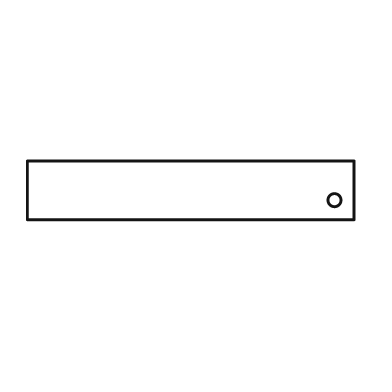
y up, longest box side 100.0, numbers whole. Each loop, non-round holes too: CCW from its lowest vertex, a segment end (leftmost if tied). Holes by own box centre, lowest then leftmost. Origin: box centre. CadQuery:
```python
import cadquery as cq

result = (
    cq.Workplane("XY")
    .moveTo(-50.0, -9.0)
    .lineTo(50.0, -9.0)
    .lineTo(50.0, 9.0)
    .lineTo(-50.0, 9.0)
    .close()
    .moveTo(44.0, -3.0)
    .circle(2.0)
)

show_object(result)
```